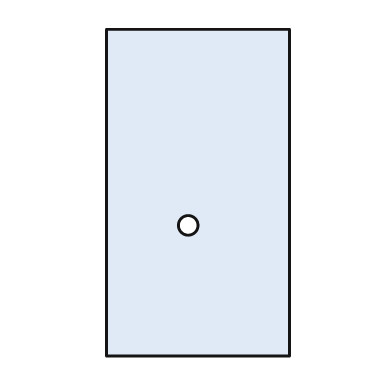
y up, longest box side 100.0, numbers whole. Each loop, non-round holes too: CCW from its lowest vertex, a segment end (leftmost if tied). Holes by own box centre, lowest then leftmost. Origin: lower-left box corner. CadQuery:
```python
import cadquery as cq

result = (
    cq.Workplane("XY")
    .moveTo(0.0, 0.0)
    .lineTo(56.0, 0.0)
    .lineTo(56.0, 100.0)
    .lineTo(0.0, 100.0)
    .close()
    .moveTo(25.0, 40.0)
    .circle(3.0)
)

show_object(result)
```